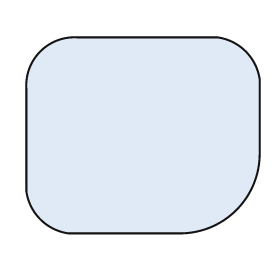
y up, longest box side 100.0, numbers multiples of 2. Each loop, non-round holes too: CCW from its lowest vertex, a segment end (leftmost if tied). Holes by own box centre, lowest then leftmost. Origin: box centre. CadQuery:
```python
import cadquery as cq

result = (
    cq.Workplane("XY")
    .moveTo(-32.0, -42.0)
    .lineTo(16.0, -42.0)
    .threePointArc((40.0, -32.0), (50.0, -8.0))
    .lineTo(50.0, 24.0)
    .threePointArc((44.0, 36.0), (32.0, 42.0))
    .lineTo(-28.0, 42.0)
    .threePointArc((-44.0, 36.0), (-50.0, 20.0))
    .lineTo(-50.0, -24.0)
    .threePointArc((-44.0, -36.0), (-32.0, -42.0))
    .close()
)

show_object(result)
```